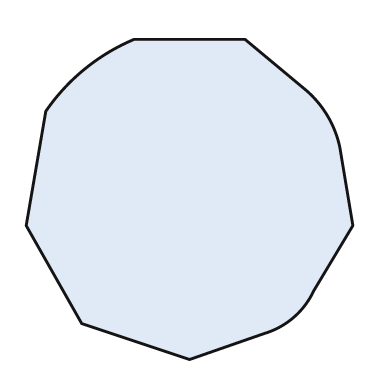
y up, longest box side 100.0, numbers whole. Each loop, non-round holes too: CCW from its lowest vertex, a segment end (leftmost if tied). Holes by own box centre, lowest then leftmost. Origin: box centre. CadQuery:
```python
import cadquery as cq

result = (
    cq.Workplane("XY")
    .moveTo(0.0, -49.0)
    .lineTo(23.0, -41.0)
    .threePointArc((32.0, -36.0), (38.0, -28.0))
    .lineTo(50.0, -8.0)
    .lineTo(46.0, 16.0)
    .threePointArc((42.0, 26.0), (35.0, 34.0))
    .lineTo(17.0, 49.0)
    .lineTo(-17.0, 49.0)
    .threePointArc((-32.0, 40.0), (-44.0, 27.0))
    .lineTo(-50.0, -8.0)
    .lineTo(-33.0, -38.0)
    .close()
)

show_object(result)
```